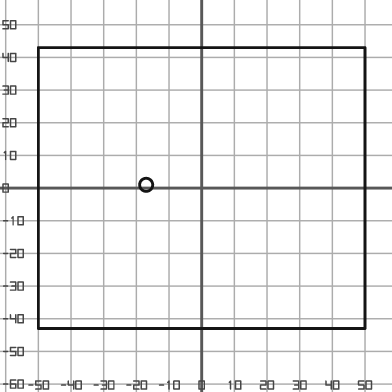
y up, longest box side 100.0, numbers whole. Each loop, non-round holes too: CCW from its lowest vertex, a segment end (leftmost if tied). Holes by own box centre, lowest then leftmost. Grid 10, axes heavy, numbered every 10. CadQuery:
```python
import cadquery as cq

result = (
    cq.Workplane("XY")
    .moveTo(-50.0, -43.0)
    .lineTo(50.0, -43.0)
    .lineTo(50.0, 43.0)
    .lineTo(-50.0, 43.0)
    .close()
    .moveTo(-17.0, 1.0)
    .circle(2.0)
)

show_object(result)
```